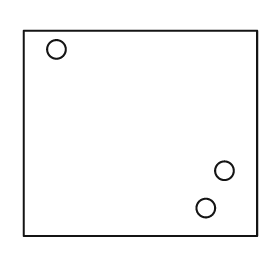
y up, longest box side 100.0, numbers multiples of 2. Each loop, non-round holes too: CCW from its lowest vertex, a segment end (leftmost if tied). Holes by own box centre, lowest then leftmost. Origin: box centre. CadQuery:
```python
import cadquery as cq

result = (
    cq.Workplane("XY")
    .moveTo(-50.0, -44.0)
    .lineTo(50.0, -44.0)
    .lineTo(50.0, 44.0)
    .lineTo(-50.0, 44.0)
    .close()
    .moveTo(28.0, -32.0)
    .circle(4.0)
    .moveTo(36.0, -16.0)
    .circle(4.0)
    .moveTo(-36.0, 36.0)
    .circle(4.0)
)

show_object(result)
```